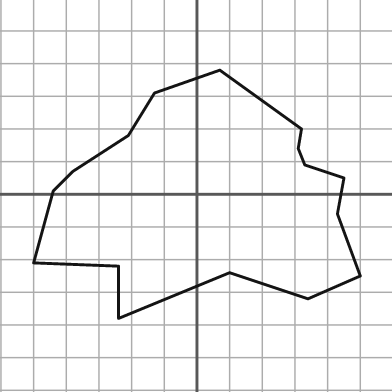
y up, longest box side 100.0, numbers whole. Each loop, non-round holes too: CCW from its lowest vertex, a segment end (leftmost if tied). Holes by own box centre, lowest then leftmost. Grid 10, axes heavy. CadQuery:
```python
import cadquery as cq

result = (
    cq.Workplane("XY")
    .moveTo(-24.0, -38.0)
    .lineTo(10.0, -24.0)
    .lineTo(34.0, -32.0)
    .lineTo(50.0, -25.0)
    .lineTo(43.0, -6.0)
    .lineTo(45.0, 5.0)
    .lineTo(33.0, 9.0)
    .lineTo(31.0, 14.0)
    .lineTo(32.0, 20.0)
    .lineTo(7.0, 38.0)
    .lineTo(-13.0, 31.0)
    .lineTo(-21.0, 18.0)
    .lineTo(-38.0, 7.0)
    .lineTo(-44.0, 1.0)
    .lineTo(-50.0, -21.0)
    .lineTo(-24.0, -22.0)
    .close()
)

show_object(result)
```